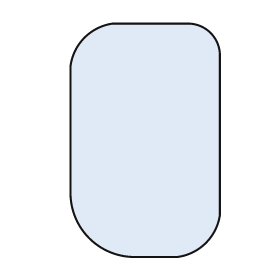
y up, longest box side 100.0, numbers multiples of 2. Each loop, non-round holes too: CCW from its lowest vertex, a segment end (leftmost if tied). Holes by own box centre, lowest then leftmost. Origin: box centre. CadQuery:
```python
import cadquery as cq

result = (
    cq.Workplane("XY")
    .moveTo(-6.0, -50.0)
    .lineTo(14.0, -50.0)
    .threePointArc((26.0, -44.0), (32.0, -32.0))
    .lineTo(32.0, 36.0)
    .threePointArc((28.0, 46.0), (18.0, 50.0))
    .lineTo(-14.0, 50.0)
    .threePointArc((-26.0, 44.0), (-32.0, 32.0))
    .lineTo(-32.0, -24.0)
    .threePointArc((-24.0, -42.0), (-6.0, -50.0))
    .close()
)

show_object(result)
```